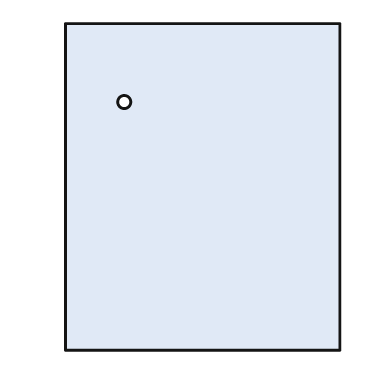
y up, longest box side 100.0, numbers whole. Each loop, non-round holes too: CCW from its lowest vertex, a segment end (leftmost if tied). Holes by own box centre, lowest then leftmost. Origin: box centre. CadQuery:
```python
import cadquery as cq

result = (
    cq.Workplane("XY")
    .moveTo(-42.0, -50.0)
    .lineTo(42.0, -50.0)
    .lineTo(42.0, 50.0)
    .lineTo(-42.0, 50.0)
    .close()
    .moveTo(-24.0, 26.0)
    .circle(2.0)
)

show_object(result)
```